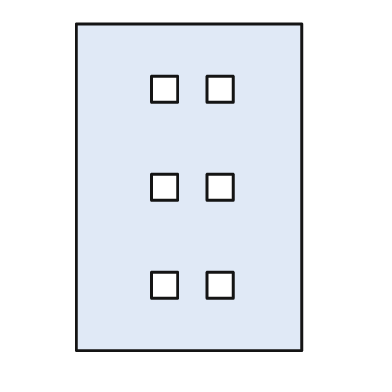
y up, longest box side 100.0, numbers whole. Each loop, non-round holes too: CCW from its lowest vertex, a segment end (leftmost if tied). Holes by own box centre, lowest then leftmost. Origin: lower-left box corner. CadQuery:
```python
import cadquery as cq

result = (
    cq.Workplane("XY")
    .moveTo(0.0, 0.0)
    .lineTo(69.0, 0.0)
    .lineTo(69.0, 100.0)
    .lineTo(0.0, 100.0)
    .close()
    .moveTo(23.0, 16.0)
    .lineTo(31.0, 16.0)
    .lineTo(31.0, 24.0)
    .lineTo(23.0, 24.0)
    .close()
    .moveTo(40.0, 16.0)
    .lineTo(48.0, 16.0)
    .lineTo(48.0, 24.0)
    .lineTo(40.0, 24.0)
    .close()
    .moveTo(23.0, 46.0)
    .lineTo(31.0, 46.0)
    .lineTo(31.0, 54.0)
    .lineTo(23.0, 54.0)
    .close()
    .moveTo(40.0, 46.0)
    .lineTo(48.0, 46.0)
    .lineTo(48.0, 54.0)
    .lineTo(40.0, 54.0)
    .close()
    .moveTo(23.0, 76.0)
    .lineTo(31.0, 76.0)
    .lineTo(31.0, 84.0)
    .lineTo(23.0, 84.0)
    .close()
    .moveTo(40.0, 76.0)
    .lineTo(48.0, 76.0)
    .lineTo(48.0, 84.0)
    .lineTo(40.0, 84.0)
    .close()
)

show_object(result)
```